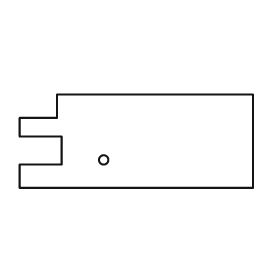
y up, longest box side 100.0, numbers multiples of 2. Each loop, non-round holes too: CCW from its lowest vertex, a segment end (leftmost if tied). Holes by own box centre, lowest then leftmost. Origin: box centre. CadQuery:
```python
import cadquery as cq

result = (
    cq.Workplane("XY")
    .moveTo(-50.0, -20.0)
    .lineTo(50.0, -20.0)
    .lineTo(50.0, 20.0)
    .lineTo(-34.0, 20.0)
    .lineTo(-34.0, 10.0)
    .lineTo(-50.0, 10.0)
    .lineTo(-50.0, 2.0)
    .lineTo(-32.0, 2.0)
    .lineTo(-32.0, -10.0)
    .lineTo(-50.0, -10.0)
    .close()
    .moveTo(-14.0, -8.0)
    .circle(2.0)
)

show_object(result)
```